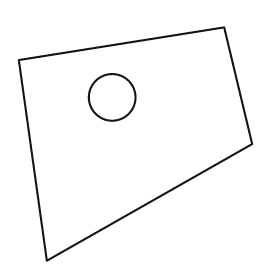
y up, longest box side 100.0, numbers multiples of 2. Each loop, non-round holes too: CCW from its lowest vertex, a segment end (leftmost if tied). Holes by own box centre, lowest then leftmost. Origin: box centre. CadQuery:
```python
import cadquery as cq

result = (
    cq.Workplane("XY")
    .moveTo(-38.0, -50.0)
    .lineTo(50.0, 0.0)
    .lineTo(38.0, 50.0)
    .lineTo(-50.0, 36.0)
    .close()
    .moveTo(-10.0, 20.0)
    .circle(10.0)
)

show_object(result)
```